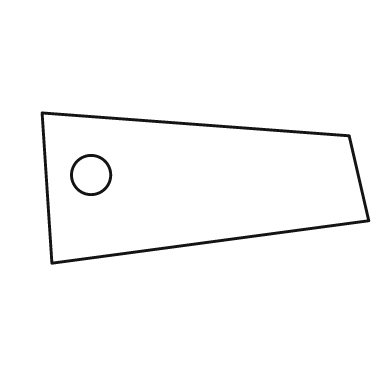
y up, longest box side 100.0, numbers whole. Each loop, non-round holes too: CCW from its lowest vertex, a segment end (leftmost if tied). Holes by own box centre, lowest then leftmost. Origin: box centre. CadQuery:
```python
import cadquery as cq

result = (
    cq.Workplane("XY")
    .moveTo(-47.0, -23.0)
    .lineTo(50.0, -10.0)
    .lineTo(44.0, 16.0)
    .lineTo(-50.0, 23.0)
    .close()
    .moveTo(-35.0, 4.0)
    .circle(6.0)
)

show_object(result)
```